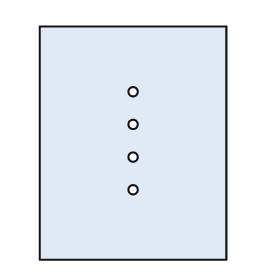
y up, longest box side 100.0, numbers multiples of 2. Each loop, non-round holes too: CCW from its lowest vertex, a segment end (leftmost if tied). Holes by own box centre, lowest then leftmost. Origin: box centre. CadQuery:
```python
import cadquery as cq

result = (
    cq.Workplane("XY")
    .moveTo(-40.0, -50.0)
    .lineTo(40.0, -50.0)
    .lineTo(40.0, 50.0)
    .lineTo(-40.0, 50.0)
    .close()
    .moveTo(0.0, -20.0)
    .circle(2.0)
    .moveTo(0.0, -6.0)
    .circle(2.0)
    .moveTo(0.0, 8.0)
    .circle(2.0)
    .moveTo(0.0, 22.0)
    .circle(2.0)
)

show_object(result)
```